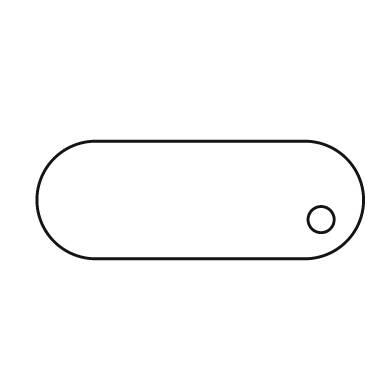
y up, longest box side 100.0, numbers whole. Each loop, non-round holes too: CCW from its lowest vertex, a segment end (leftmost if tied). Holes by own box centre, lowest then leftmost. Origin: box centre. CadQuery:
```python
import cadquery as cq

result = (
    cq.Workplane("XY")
    .moveTo(-32.0, -18.0)
    .lineTo(32.0, -18.0)
    .threePointArc((50.0, 0.0), (32.0, 18.0))
    .lineTo(-32.0, 18.0)
    .threePointArc((-50.0, 0.0), (-32.0, -18.0))
    .close()
    .moveTo(37.0, -6.0)
    .circle(4.0)
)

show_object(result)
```